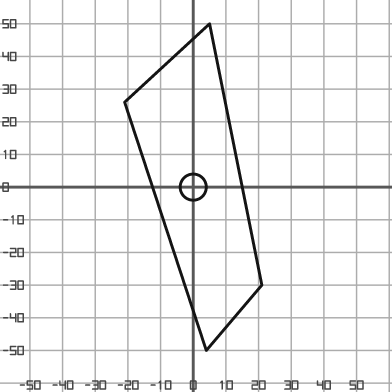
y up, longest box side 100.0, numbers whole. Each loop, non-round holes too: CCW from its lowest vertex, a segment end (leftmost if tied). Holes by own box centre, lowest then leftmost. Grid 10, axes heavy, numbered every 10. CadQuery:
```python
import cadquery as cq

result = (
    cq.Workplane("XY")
    .moveTo(4.0, -50.0)
    .lineTo(21.0, -30.0)
    .lineTo(5.0, 50.0)
    .lineTo(-21.0, 26.0)
    .close()
    .moveTo(0.0, 0.0)
    .circle(4.0)
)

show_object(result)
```